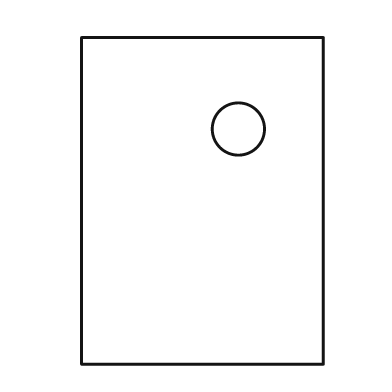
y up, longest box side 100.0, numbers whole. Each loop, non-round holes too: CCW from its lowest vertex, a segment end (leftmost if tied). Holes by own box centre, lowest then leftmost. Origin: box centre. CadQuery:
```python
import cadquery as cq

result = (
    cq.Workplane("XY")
    .moveTo(-37.0, -50.0)
    .lineTo(37.0, -50.0)
    .lineTo(37.0, 50.0)
    .lineTo(-37.0, 50.0)
    .close()
    .moveTo(11.0, 22.0)
    .circle(8.0)
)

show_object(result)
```